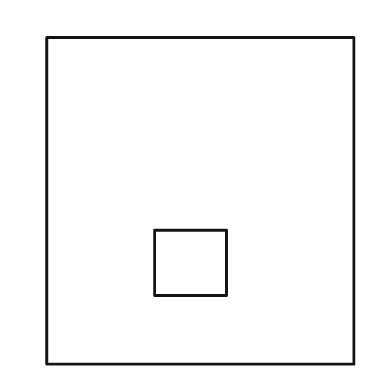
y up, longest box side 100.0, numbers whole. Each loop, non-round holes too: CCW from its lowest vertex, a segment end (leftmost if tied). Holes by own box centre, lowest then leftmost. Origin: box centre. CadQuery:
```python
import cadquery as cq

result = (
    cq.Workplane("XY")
    .moveTo(-47.0, -50.0)
    .lineTo(47.0, -50.0)
    .lineTo(47.0, 50.0)
    .lineTo(-47.0, 50.0)
    .close()
    .moveTo(-14.0, -29.0)
    .lineTo(8.0, -29.0)
    .lineTo(8.0, -9.0)
    .lineTo(-14.0, -9.0)
    .close()
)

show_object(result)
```